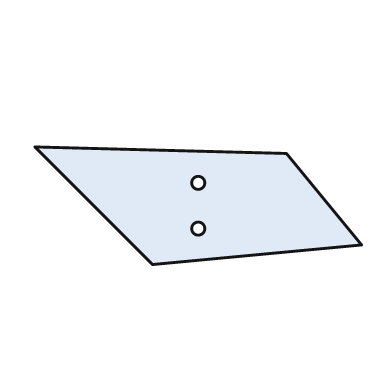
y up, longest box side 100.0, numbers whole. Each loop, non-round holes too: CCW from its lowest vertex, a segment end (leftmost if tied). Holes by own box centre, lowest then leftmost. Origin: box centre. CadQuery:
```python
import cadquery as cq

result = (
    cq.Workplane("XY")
    .moveTo(-14.0, -18.0)
    .lineTo(50.0, -12.0)
    .lineTo(27.0, 16.0)
    .lineTo(-50.0, 18.0)
    .close()
    .moveTo(0.0, -7.0)
    .circle(2.0)
    .moveTo(0.0, 7.0)
    .circle(2.0)
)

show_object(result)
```